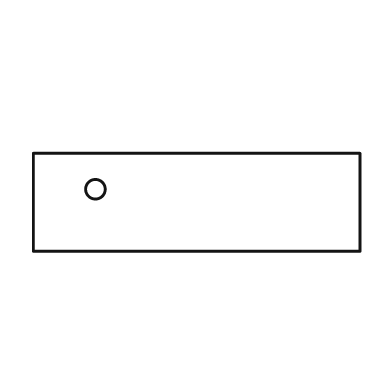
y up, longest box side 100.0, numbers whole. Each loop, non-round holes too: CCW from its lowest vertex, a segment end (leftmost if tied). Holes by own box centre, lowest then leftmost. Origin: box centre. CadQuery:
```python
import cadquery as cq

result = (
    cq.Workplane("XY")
    .moveTo(-50.0, -15.0)
    .lineTo(50.0, -15.0)
    .lineTo(50.0, 15.0)
    .lineTo(-50.0, 15.0)
    .close()
    .moveTo(-31.0, 4.0)
    .circle(3.0)
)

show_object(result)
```